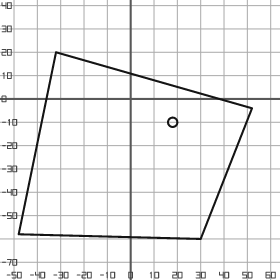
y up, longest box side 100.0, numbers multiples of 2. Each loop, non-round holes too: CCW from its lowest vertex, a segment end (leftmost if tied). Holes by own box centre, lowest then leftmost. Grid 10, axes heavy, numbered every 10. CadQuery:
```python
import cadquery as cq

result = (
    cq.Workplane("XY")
    .moveTo(30.0, -60.0)
    .lineTo(52.0, -4.0)
    .lineTo(-32.0, 20.0)
    .lineTo(-48.0, -58.0)
    .close()
    .moveTo(18.0, -10.0)
    .circle(2.0)
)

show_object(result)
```